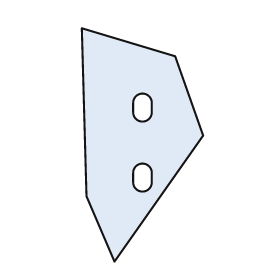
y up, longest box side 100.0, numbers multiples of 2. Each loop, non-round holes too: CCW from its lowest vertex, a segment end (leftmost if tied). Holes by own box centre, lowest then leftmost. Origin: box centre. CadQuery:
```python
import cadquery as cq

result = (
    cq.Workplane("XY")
    .moveTo(-12.0, -50.0)
    .lineTo(26.0, 4.0)
    .lineTo(14.0, 38.0)
    .lineTo(-26.0, 50.0)
    .lineTo(-24.0, -22.0)
    .close()
    .moveTo(-4.0, -16.0)
    .threePointArc((0.0, -20.0), (4.0, -16.0))
    .lineTo(4.0, -12.0)
    .threePointArc((0.0, -8.0), (-4.0, -12.0))
    .close()
    .moveTo(-4.0, 14.0)
    .threePointArc((0.0, 10.0), (4.0, 14.0))
    .lineTo(4.0, 18.0)
    .threePointArc((0.0, 22.0), (-4.0, 18.0))
    .close()
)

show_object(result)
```